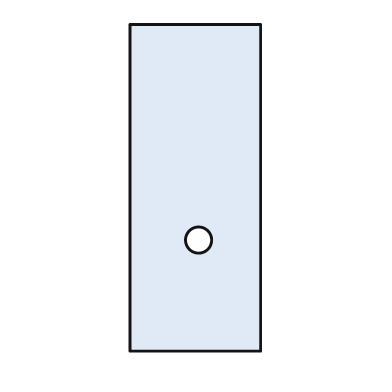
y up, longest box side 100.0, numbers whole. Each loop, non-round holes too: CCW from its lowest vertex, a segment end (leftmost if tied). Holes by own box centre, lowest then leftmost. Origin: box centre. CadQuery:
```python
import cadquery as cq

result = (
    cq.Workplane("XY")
    .moveTo(-20.0, -50.0)
    .lineTo(20.0, -50.0)
    .lineTo(20.0, 50.0)
    .lineTo(-20.0, 50.0)
    .close()
    .moveTo(1.0, -16.0)
    .circle(4.0)
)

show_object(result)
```